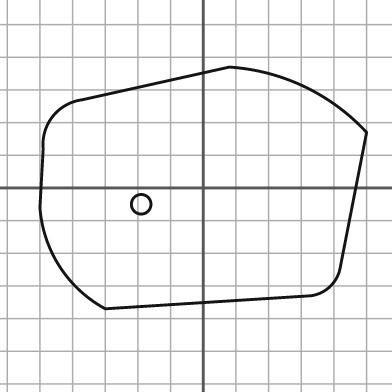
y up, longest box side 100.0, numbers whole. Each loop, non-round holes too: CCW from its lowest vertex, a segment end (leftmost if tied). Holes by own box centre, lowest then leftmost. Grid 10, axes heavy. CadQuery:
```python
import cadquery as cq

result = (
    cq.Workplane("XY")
    .moveTo(-30.0, -37.0)
    .lineTo(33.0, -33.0)
    .threePointArc((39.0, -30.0), (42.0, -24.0))
    .lineTo(50.0, 17.0)
    .threePointArc((31.0, 31.0), (8.0, 37.0))
    .lineTo(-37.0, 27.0)
    .threePointArc((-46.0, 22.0), (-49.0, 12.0))
    .lineTo(-50.0, -6.0)
    .threePointArc((-44.0, -24.0), (-30.0, -37.0))
    .close()
    .moveTo(-19.0, -5.0)
    .circle(3.0)
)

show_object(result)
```